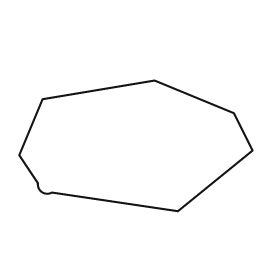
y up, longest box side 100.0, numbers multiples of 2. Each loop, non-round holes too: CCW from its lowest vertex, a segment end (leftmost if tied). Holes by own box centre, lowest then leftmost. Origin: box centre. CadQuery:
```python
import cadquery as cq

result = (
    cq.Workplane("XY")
    .moveTo(18.0, -28.0)
    .lineTo(50.0, -2.0)
    .lineTo(42.0, 14.0)
    .lineTo(8.0, 28.0)
    .lineTo(-40.0, 20.0)
    .lineTo(-50.0, -4.0)
    .lineTo(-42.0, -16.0)
    .threePointArc((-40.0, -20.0), (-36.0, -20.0))
    .close()
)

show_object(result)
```